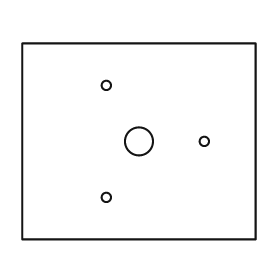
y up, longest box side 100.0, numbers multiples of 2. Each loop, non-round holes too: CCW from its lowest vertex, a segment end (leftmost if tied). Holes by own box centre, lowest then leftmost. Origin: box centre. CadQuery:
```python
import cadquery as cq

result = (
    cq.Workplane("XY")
    .moveTo(-50.0, -42.0)
    .lineTo(50.0, -42.0)
    .lineTo(50.0, 42.0)
    .lineTo(-50.0, 42.0)
    .close()
    .moveTo(-14.0, -24.0)
    .circle(2.0)
    .moveTo(0.0, 0.0)
    .circle(6.0)
    .moveTo(28.0, 0.0)
    .circle(2.0)
    .moveTo(-14.0, 24.0)
    .circle(2.0)
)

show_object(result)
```